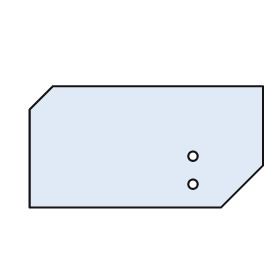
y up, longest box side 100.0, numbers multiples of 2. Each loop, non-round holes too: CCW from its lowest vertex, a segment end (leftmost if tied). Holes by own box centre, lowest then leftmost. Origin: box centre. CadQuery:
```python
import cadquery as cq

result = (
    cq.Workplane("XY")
    .moveTo(-50.0, -26.0)
    .lineTo(32.0, -26.0)
    .lineTo(50.0, -8.0)
    .lineTo(50.0, 26.0)
    .lineTo(-40.0, 26.0)
    .lineTo(-50.0, 16.0)
    .close()
    .moveTo(20.0, -16.0)
    .circle(2.0)
    .moveTo(20.0, -4.0)
    .circle(2.0)
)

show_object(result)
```